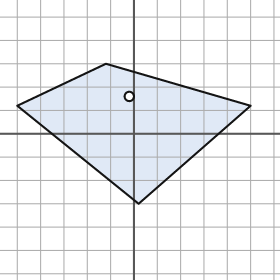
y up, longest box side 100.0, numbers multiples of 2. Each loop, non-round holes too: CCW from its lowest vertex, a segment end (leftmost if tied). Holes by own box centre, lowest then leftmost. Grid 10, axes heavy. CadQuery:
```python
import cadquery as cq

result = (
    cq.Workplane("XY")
    .moveTo(2.0, -30.0)
    .lineTo(50.0, 12.0)
    .lineTo(-12.0, 30.0)
    .lineTo(-50.0, 12.0)
    .close()
    .moveTo(-2.0, 16.0)
    .circle(2.0)
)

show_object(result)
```